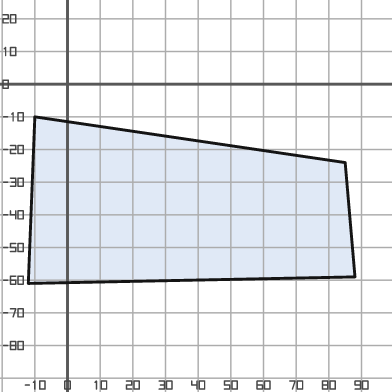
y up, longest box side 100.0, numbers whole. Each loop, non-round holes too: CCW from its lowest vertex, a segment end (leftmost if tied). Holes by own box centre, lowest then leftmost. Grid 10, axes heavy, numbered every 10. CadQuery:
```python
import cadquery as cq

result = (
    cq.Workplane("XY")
    .moveTo(-12.0, -61.0)
    .lineTo(88.0, -59.0)
    .lineTo(85.0, -24.0)
    .lineTo(-10.0, -10.0)
    .close()
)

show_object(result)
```